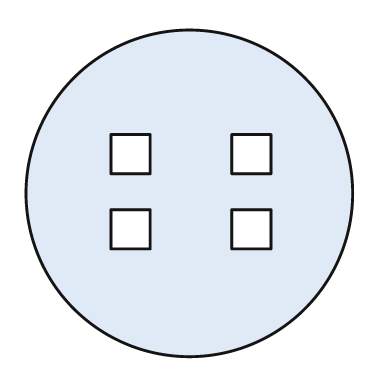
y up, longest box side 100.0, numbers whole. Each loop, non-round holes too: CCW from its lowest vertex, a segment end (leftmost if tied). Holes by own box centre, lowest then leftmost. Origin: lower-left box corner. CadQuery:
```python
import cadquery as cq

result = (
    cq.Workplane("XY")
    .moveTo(50.0, 50.0)
    .circle(50.0)
    .moveTo(26.0, 33.0)
    .lineTo(38.0, 33.0)
    .lineTo(38.0, 45.0)
    .lineTo(26.0, 45.0)
    .close()
    .moveTo(63.0, 33.0)
    .lineTo(75.0, 33.0)
    .lineTo(75.0, 45.0)
    .lineTo(63.0, 45.0)
    .close()
    .moveTo(26.0, 56.0)
    .lineTo(38.0, 56.0)
    .lineTo(38.0, 68.0)
    .lineTo(26.0, 68.0)
    .close()
    .moveTo(63.0, 56.0)
    .lineTo(75.0, 56.0)
    .lineTo(75.0, 68.0)
    .lineTo(63.0, 68.0)
    .close()
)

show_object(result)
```